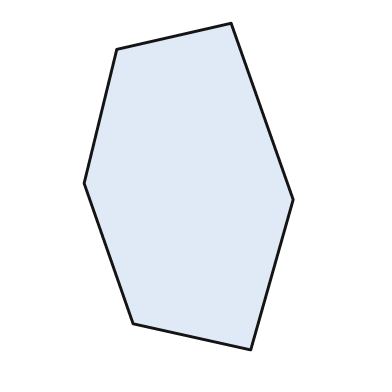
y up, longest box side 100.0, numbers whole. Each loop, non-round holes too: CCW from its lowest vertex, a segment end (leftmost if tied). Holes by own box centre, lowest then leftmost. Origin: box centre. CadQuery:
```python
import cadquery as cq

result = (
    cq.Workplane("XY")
    .moveTo(19.0, -50.0)
    .lineTo(32.0, -4.0)
    .lineTo(13.0, 50.0)
    .lineTo(-22.0, 42.0)
    .lineTo(-32.0, 1.0)
    .lineTo(-17.0, -42.0)
    .close()
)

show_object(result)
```